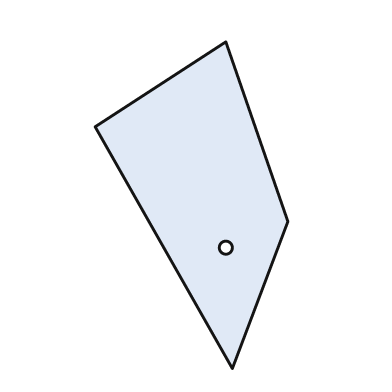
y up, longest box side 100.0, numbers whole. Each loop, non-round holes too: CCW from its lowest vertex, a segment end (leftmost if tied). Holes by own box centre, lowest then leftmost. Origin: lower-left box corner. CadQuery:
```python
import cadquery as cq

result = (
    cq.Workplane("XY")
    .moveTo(42.0, 0.0)
    .lineTo(59.0, 45.0)
    .lineTo(40.0, 100.0)
    .lineTo(0.0, 74.0)
    .close()
    .moveTo(40.0, 37.0)
    .circle(2.0)
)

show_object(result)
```